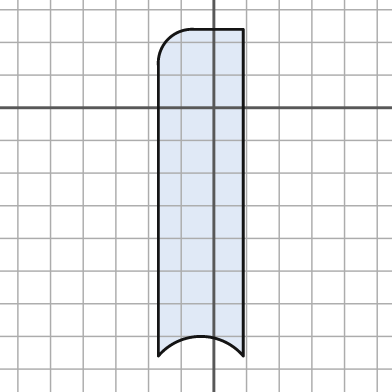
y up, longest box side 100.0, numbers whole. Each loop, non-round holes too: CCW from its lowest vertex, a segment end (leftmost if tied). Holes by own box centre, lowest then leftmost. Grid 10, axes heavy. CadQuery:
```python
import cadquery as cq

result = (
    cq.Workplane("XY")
    .moveTo(-17.0, -76.0)
    .threePointArc((-4.0, -70.0), (9.0, -76.0))
    .lineTo(9.0, 24.0)
    .lineTo(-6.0, 24.0)
    .threePointArc((-14.0, 21.0), (-17.0, 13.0))
    .close()
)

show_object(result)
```